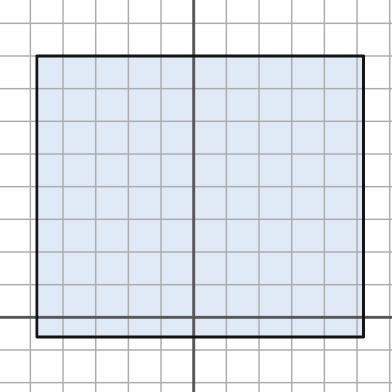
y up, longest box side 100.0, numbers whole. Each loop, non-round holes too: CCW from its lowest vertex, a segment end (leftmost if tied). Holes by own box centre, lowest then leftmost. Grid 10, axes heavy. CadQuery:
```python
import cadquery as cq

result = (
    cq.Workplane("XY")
    .moveTo(-48.0, -6.0)
    .lineTo(52.0, -6.0)
    .lineTo(52.0, 80.0)
    .lineTo(-48.0, 80.0)
    .close()
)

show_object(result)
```